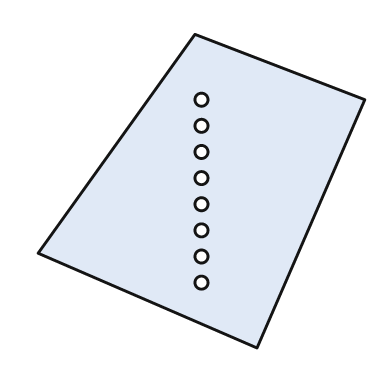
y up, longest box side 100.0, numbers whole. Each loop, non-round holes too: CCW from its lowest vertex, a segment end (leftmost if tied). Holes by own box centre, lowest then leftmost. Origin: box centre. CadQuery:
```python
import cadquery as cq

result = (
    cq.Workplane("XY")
    .moveTo(17.0, -48.0)
    .lineTo(50.0, 28.0)
    .lineTo(-2.0, 48.0)
    .lineTo(-50.0, -19.0)
    .close()
    .moveTo(0.0, -28.0)
    .circle(2.0)
    .moveTo(0.0, -20.0)
    .circle(2.0)
    .moveTo(0.0, -12.0)
    .circle(2.0)
    .moveTo(0.0, -4.0)
    .circle(2.0)
    .moveTo(0.0, 4.0)
    .circle(2.0)
    .moveTo(0.0, 12.0)
    .circle(2.0)
    .moveTo(0.0, 20.0)
    .circle(2.0)
    .moveTo(0.0, 28.0)
    .circle(2.0)
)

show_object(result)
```